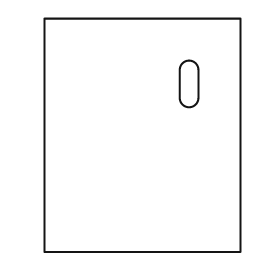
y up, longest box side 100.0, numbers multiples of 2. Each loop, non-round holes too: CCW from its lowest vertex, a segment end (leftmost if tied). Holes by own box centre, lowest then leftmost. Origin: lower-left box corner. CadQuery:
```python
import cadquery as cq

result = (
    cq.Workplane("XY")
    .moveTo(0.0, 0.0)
    .lineTo(84.0, 0.0)
    .lineTo(84.0, 100.0)
    .lineTo(0.0, 100.0)
    .close()
    .moveTo(58.0, 66.0)
    .threePointArc((62.0, 62.0), (66.0, 66.0))
    .lineTo(66.0, 78.0)
    .threePointArc((62.0, 82.0), (58.0, 78.0))
    .close()
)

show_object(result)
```